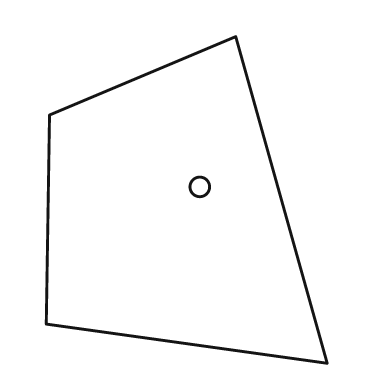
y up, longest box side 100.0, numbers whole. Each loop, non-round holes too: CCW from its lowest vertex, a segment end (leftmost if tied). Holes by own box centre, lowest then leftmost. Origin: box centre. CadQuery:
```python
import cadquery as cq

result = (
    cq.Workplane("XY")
    .moveTo(43.0, -50.0)
    .lineTo(15.0, 50.0)
    .lineTo(-42.0, 26.0)
    .lineTo(-43.0, -38.0)
    .close()
    .moveTo(4.0, 4.0)
    .circle(3.0)
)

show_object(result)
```